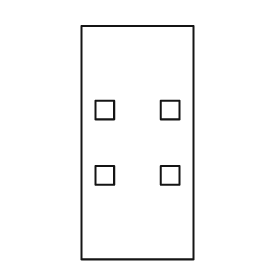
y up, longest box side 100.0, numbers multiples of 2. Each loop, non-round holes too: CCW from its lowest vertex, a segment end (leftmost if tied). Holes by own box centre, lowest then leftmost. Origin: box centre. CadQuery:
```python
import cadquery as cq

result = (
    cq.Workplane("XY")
    .moveTo(-24.0, -50.0)
    .lineTo(24.0, -50.0)
    .lineTo(24.0, 50.0)
    .lineTo(-24.0, 50.0)
    .close()
    .moveTo(-18.0, -18.0)
    .lineTo(-10.0, -18.0)
    .lineTo(-10.0, -10.0)
    .lineTo(-18.0, -10.0)
    .close()
    .moveTo(10.0, -18.0)
    .lineTo(18.0, -18.0)
    .lineTo(18.0, -10.0)
    .lineTo(10.0, -10.0)
    .close()
    .moveTo(-18.0, 10.0)
    .lineTo(-10.0, 10.0)
    .lineTo(-10.0, 18.0)
    .lineTo(-18.0, 18.0)
    .close()
    .moveTo(10.0, 10.0)
    .lineTo(18.0, 10.0)
    .lineTo(18.0, 18.0)
    .lineTo(10.0, 18.0)
    .close()
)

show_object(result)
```